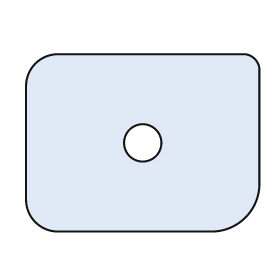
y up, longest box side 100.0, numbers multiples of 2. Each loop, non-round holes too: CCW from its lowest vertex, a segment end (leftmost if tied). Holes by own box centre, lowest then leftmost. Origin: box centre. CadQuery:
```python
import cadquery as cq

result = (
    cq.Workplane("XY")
    .moveTo(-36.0, -38.0)
    .lineTo(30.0, -38.0)
    .threePointArc((44.0, -32.0), (50.0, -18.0))
    .lineTo(50.0, 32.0)
    .threePointArc((48.0, 36.0), (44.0, 38.0))
    .lineTo(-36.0, 38.0)
    .threePointArc((-46.0, 34.0), (-50.0, 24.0))
    .lineTo(-50.0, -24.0)
    .threePointArc((-46.0, -34.0), (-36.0, -38.0))
    .close()
    .moveTo(0.0, 0.0)
    .circle(8.0)
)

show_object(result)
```